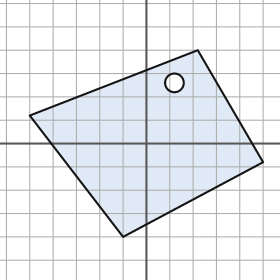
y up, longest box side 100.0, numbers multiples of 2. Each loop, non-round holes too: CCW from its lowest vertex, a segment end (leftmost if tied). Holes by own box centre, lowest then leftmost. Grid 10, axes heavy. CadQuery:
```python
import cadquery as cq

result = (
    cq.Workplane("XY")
    .moveTo(-10.0, -40.0)
    .lineTo(50.0, -8.0)
    .lineTo(22.0, 40.0)
    .lineTo(-50.0, 12.0)
    .close()
    .moveTo(12.0, 26.0)
    .circle(4.0)
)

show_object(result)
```